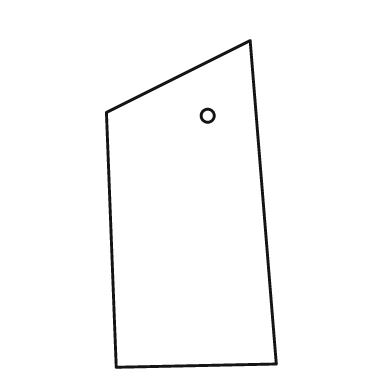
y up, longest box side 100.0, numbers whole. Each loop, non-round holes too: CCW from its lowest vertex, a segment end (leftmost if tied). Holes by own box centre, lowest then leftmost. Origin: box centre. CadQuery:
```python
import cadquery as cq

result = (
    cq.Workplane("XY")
    .moveTo(-23.0, -50.0)
    .lineTo(26.0, -49.0)
    .lineTo(18.0, 50.0)
    .lineTo(-26.0, 28.0)
    .close()
    .moveTo(5.0, 27.0)
    .circle(2.0)
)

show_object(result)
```